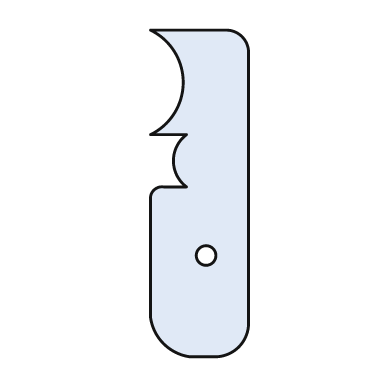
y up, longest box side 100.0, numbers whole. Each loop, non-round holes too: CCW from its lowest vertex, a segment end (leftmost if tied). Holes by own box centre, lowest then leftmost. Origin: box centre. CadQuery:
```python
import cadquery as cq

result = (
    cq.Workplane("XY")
    .moveTo(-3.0, -50.0)
    .lineTo(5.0, -50.0)
    .threePointArc((12.0, -47.0), (15.0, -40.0))
    .lineTo(15.0, 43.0)
    .threePointArc((13.0, 48.0), (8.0, 50.0))
    .lineTo(-15.0, 50.0)
    .threePointArc((-5.0, 34.0), (-15.0, 18.0))
    .lineTo(-4.0, 18.0)
    .threePointArc((-8.0, 10.0), (-4.0, 2.0))
    .lineTo(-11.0, 2.0)
    .threePointArc((-14.0, 1.0), (-15.0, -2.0))
    .lineTo(-15.0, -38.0)
    .threePointArc((-11.0, -46.0), (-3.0, -50.0))
    .close()
    .moveTo(2.0, -19.0)
    .circle(3.0)
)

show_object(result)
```